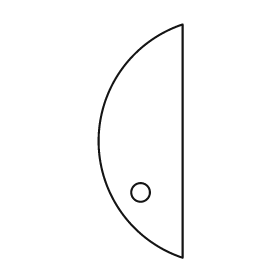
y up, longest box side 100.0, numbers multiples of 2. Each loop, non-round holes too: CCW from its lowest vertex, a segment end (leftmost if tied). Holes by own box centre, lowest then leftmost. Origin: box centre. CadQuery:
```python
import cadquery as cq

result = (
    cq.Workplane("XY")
    .moveTo(18.0, -50.0)
    .lineTo(18.0, 50.0)
    .threePointArc((-18.0, 0.0), (18.0, -50.0))
    .close()
    .moveTo(0.0, -22.0)
    .circle(4.0)
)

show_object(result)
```